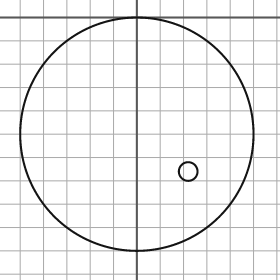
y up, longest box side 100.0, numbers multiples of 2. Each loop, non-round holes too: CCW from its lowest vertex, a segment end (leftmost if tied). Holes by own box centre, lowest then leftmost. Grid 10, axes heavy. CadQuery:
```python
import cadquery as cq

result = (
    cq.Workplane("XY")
    .moveTo(0.0, -50.0)
    .circle(50.0)
    .moveTo(22.0, -66.0)
    .circle(4.0)
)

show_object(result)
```